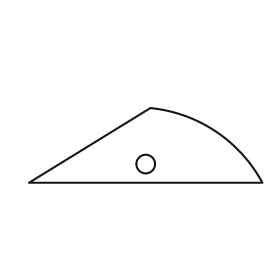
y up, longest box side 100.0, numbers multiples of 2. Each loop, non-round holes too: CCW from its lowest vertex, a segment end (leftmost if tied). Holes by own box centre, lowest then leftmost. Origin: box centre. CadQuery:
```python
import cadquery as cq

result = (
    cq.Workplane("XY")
    .moveTo(-50.0, -16.0)
    .lineTo(50.0, -16.0)
    .threePointArc((30.0, 6.0), (2.0, 16.0))
    .close()
    .moveTo(0.0, -8.0)
    .circle(4.0)
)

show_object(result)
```